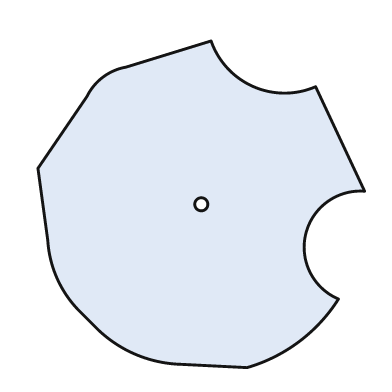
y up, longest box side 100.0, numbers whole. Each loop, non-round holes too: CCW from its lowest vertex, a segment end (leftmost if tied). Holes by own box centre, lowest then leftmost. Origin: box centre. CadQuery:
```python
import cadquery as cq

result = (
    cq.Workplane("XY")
    .moveTo(14.0, -50.0)
    .threePointArc((30.0, -42.0), (42.0, -29.0))
    .threePointArc((32.0, -9.0), (50.0, 4.0))
    .lineTo(35.0, 36.0)
    .threePointArc((16.0, 36.0), (3.0, 50.0))
    .lineTo(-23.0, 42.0)
    .threePointArc((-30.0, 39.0), (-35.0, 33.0))
    .lineTo(-50.0, 11.0)
    .lineTo(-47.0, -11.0)
    .threePointArc((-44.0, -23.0), (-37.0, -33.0))
    .lineTo(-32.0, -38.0)
    .threePointArc((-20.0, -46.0), (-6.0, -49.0))
    .close()
    .moveTo(0.0, 0.0)
    .circle(2.0)
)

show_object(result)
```